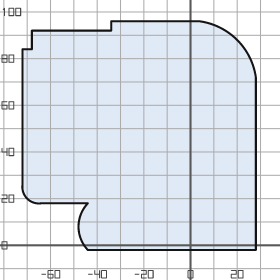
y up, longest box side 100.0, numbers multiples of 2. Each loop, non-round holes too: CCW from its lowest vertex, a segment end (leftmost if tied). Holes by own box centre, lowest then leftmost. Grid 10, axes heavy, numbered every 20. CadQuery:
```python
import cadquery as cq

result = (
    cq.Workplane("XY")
    .moveTo(-44.0, -2.0)
    .lineTo(28.0, -2.0)
    .lineTo(28.0, 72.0)
    .threePointArc((20.0, 88.0), (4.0, 96.0))
    .lineTo(-34.0, 96.0)
    .lineTo(-34.0, 92.0)
    .lineTo(-68.0, 92.0)
    .lineTo(-68.0, 84.0)
    .lineTo(-72.0, 84.0)
    .lineTo(-72.0, 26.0)
    .threePointArc((-70.0, 20.0), (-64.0, 18.0))
    .lineTo(-44.0, 18.0)
    .threePointArc((-48.0, 8.0), (-44.0, -2.0))
    .close()
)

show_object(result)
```